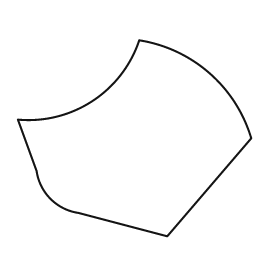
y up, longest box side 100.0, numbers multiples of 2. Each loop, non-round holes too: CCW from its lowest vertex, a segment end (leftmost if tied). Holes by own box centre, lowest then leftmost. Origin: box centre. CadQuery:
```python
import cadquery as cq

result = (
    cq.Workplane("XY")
    .moveTo(14.0, -42.0)
    .lineTo(50.0, 0.0)
    .threePointArc((32.0, 28.0), (2.0, 42.0))
    .threePointArc((-18.0, 16.0), (-50.0, 8.0))
    .lineTo(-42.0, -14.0)
    .threePointArc((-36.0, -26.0), (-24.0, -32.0))
    .close()
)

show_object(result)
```